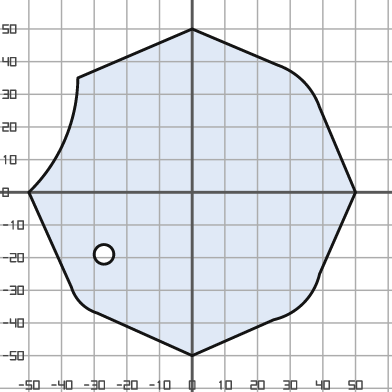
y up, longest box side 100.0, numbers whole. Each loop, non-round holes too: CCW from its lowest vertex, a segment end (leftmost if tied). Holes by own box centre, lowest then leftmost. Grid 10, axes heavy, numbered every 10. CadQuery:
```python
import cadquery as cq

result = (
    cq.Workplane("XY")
    .moveTo(0.0, -50.0)
    .lineTo(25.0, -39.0)
    .threePointArc((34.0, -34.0), (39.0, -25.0))
    .lineTo(50.0, 0.0)
    .lineTo(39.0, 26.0)
    .threePointArc((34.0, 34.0), (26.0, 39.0))
    .lineTo(0.0, 50.0)
    .lineTo(-35.0, 35.0)
    .threePointArc((-39.0, 16.0), (-50.0, 0.0))
    .lineTo(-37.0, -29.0)
    .threePointArc((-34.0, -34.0), (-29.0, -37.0))
    .close()
    .moveTo(-27.0, -19.0)
    .circle(3.0)
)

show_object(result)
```